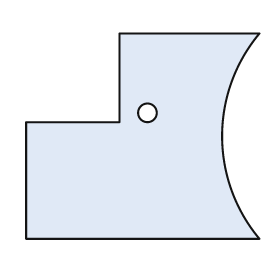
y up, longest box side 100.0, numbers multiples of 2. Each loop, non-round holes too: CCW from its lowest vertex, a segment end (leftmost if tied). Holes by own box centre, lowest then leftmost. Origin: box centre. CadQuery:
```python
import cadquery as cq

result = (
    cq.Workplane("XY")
    .moveTo(-50.0, -44.0)
    .lineTo(50.0, -44.0)
    .threePointArc((34.0, 0.0), (50.0, 44.0))
    .lineTo(-10.0, 44.0)
    .lineTo(-10.0, 6.0)
    .lineTo(-50.0, 6.0)
    .close()
    .moveTo(2.0, 10.0)
    .circle(4.0)
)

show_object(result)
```